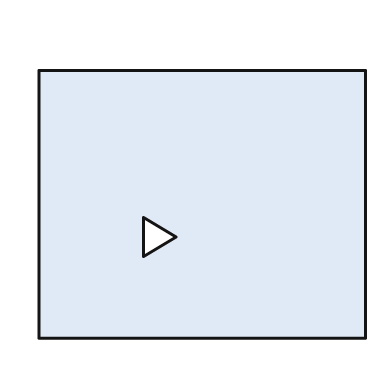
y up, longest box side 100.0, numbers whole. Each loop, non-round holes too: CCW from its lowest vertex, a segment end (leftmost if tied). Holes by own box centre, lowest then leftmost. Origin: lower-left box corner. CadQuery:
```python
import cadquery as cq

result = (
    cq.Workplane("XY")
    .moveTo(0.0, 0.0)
    .lineTo(100.0, 0.0)
    .lineTo(100.0, 82.0)
    .lineTo(0.0, 82.0)
    .close()
    .moveTo(32.0, 25.0)
    .lineTo(42.0, 31.0)
    .lineTo(32.0, 37.0)
    .close()
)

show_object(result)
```